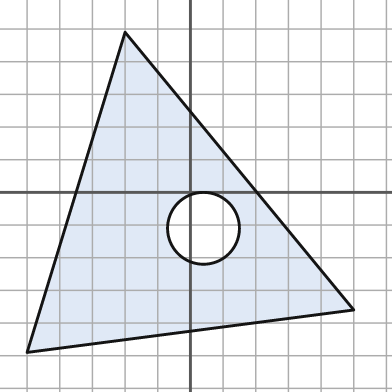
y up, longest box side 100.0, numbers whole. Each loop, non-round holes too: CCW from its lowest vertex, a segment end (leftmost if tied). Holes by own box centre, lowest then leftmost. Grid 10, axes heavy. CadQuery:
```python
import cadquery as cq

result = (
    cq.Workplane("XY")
    .moveTo(-50.0, -49.0)
    .lineTo(50.0, -36.0)
    .lineTo(-20.0, 49.0)
    .close()
    .moveTo(4.0, -11.0)
    .circle(11.0)
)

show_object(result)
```